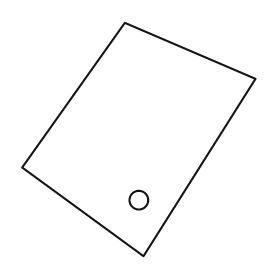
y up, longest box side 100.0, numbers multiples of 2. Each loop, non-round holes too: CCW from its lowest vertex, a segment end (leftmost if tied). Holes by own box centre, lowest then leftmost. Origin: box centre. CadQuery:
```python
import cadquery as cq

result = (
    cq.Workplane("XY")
    .moveTo(2.0, -50.0)
    .lineTo(50.0, 26.0)
    .lineTo(-6.0, 50.0)
    .lineTo(-50.0, -12.0)
    .close()
    .moveTo(0.0, -26.0)
    .circle(4.0)
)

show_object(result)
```